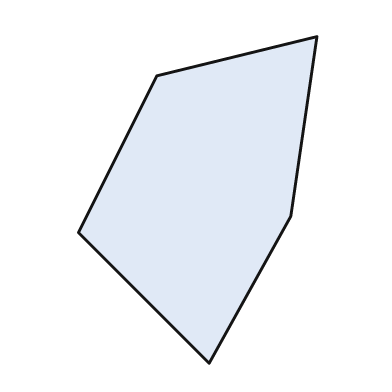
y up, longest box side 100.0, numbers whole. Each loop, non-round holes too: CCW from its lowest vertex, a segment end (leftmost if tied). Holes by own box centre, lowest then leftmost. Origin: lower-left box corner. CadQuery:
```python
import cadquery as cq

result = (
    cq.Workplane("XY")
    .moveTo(40.0, 0.0)
    .lineTo(65.0, 45.0)
    .lineTo(73.0, 100.0)
    .lineTo(24.0, 88.0)
    .lineTo(0.0, 40.0)
    .close()
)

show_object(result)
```